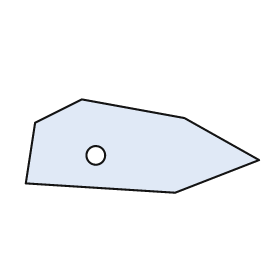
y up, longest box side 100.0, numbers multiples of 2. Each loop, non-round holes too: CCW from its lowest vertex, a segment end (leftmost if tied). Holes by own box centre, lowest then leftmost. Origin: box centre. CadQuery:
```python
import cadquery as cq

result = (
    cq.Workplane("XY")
    .moveTo(14.0, -20.0)
    .lineTo(50.0, -6.0)
    .lineTo(18.0, 12.0)
    .lineTo(-26.0, 20.0)
    .lineTo(-46.0, 10.0)
    .lineTo(-50.0, -16.0)
    .close()
    .moveTo(-20.0, -4.0)
    .circle(4.0)
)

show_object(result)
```